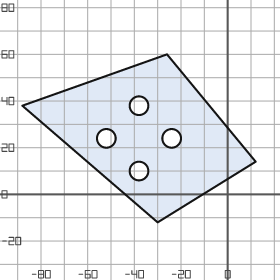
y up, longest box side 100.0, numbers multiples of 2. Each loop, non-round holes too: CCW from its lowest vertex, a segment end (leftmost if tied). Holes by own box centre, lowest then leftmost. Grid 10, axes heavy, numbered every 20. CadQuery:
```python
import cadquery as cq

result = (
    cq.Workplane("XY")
    .moveTo(-30.0, -12.0)
    .lineTo(12.0, 14.0)
    .lineTo(-26.0, 60.0)
    .lineTo(-88.0, 38.0)
    .close()
    .moveTo(-38.0, 10.0)
    .circle(4.0)
    .moveTo(-52.0, 24.0)
    .circle(4.0)
    .moveTo(-24.0, 24.0)
    .circle(4.0)
    .moveTo(-38.0, 38.0)
    .circle(4.0)
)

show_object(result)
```